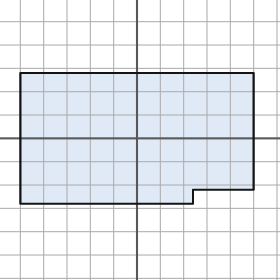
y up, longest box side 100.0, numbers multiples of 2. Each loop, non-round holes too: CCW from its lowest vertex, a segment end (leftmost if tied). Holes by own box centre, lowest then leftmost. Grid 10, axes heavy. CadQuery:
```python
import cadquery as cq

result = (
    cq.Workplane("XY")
    .moveTo(-50.0, -28.0)
    .lineTo(24.0, -28.0)
    .lineTo(24.0, -22.0)
    .lineTo(50.0, -22.0)
    .lineTo(50.0, 28.0)
    .lineTo(-50.0, 28.0)
    .close()
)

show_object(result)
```